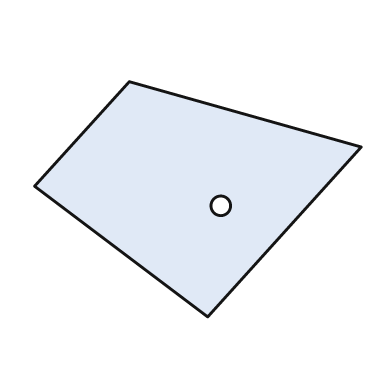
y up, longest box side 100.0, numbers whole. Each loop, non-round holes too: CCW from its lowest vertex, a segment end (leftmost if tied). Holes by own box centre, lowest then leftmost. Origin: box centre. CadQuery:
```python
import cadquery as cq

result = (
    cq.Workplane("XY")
    .moveTo(3.0, -36.0)
    .lineTo(50.0, 16.0)
    .lineTo(-21.0, 36.0)
    .lineTo(-50.0, 4.0)
    .close()
    .moveTo(7.0, -2.0)
    .circle(3.0)
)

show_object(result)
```